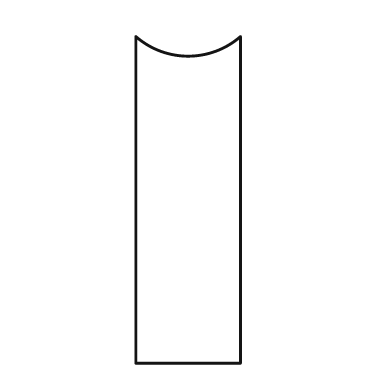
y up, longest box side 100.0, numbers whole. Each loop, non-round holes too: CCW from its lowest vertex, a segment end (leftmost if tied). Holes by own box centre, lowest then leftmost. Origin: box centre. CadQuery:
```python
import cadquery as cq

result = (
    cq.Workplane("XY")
    .moveTo(-16.0, -50.0)
    .lineTo(16.0, -50.0)
    .lineTo(16.0, 50.0)
    .threePointArc((0.0, 44.0), (-16.0, 50.0))
    .close()
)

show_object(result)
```